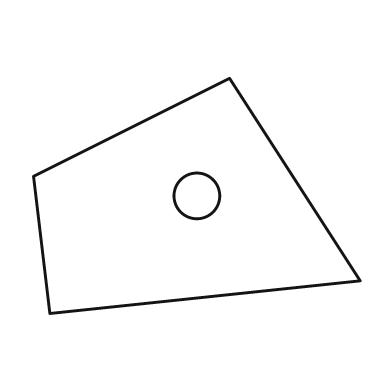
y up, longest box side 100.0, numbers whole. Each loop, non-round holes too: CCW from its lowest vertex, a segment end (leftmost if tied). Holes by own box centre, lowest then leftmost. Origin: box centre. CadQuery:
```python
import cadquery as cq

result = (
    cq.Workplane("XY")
    .moveTo(-45.0, -36.0)
    .lineTo(50.0, -26.0)
    .lineTo(10.0, 36.0)
    .lineTo(-50.0, 6.0)
    .close()
    .moveTo(0.0, 0.0)
    .circle(7.0)
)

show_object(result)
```